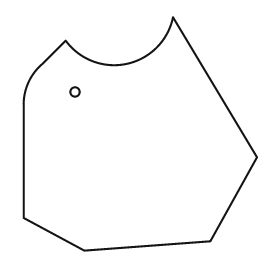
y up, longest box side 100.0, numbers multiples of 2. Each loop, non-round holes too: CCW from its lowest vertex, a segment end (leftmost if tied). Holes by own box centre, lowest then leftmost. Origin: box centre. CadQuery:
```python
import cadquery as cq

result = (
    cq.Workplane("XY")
    .moveTo(-24.0, -50.0)
    .lineTo(30.0, -46.0)
    .lineTo(50.0, -10.0)
    .lineTo(14.0, 50.0)
    .threePointArc((-6.0, 30.0), (-32.0, 40.0))
    .lineTo(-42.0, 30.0)
    .threePointArc((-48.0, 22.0), (-50.0, 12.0))
    .lineTo(-50.0, -36.0)
    .close()
    .moveTo(-28.0, 18.0)
    .circle(2.0)
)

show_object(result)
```